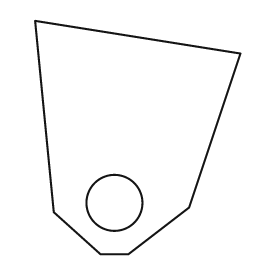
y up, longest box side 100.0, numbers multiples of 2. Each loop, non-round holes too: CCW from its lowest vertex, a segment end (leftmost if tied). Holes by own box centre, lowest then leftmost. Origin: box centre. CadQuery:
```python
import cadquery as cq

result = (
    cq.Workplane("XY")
    .moveTo(-16.0, -50.0)
    .lineTo(-4.0, -50.0)
    .lineTo(22.0, -30.0)
    .lineTo(44.0, 36.0)
    .lineTo(-44.0, 50.0)
    .lineTo(-36.0, -32.0)
    .close()
    .moveTo(-10.0, -28.0)
    .circle(12.0)
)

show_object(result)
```